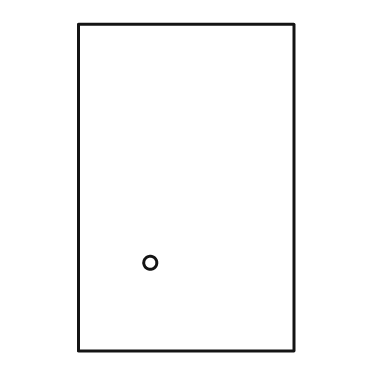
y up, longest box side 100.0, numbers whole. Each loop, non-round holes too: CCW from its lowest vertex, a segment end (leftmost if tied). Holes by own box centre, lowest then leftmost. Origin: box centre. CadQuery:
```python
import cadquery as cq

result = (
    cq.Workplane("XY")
    .moveTo(-33.0, -50.0)
    .lineTo(33.0, -50.0)
    .lineTo(33.0, 50.0)
    .lineTo(-33.0, 50.0)
    .close()
    .moveTo(-11.0, -23.0)
    .circle(2.0)
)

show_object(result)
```